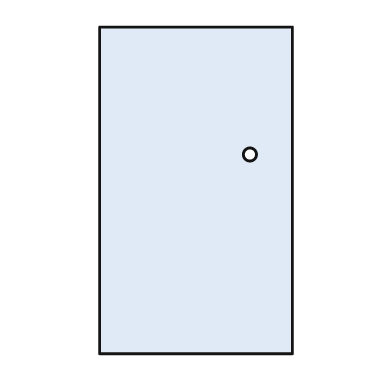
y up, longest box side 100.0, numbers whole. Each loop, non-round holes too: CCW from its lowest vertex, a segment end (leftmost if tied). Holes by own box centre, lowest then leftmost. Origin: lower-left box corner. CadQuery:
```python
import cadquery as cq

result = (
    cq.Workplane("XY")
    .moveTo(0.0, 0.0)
    .lineTo(59.0, 0.0)
    .lineTo(59.0, 100.0)
    .lineTo(0.0, 100.0)
    .close()
    .moveTo(46.0, 61.0)
    .circle(2.0)
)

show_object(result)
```